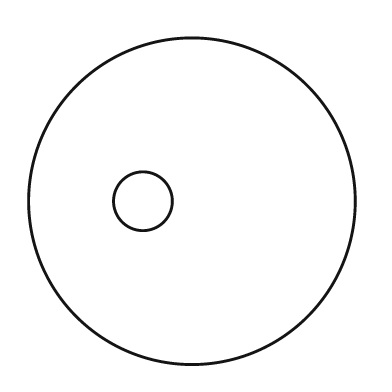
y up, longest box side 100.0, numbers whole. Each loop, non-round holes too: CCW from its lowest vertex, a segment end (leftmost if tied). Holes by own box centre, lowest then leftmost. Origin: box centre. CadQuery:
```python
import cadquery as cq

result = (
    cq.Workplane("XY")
    .moveTo(0.0, 0.0)
    .circle(50.0)
    .moveTo(-15.0, 0.0)
    .circle(9.0)
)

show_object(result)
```